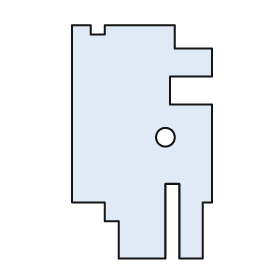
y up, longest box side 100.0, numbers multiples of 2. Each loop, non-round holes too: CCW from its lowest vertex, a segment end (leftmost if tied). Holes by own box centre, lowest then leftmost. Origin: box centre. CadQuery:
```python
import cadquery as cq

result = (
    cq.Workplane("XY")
    .moveTo(-10.0, -50.0)
    .lineTo(10.0, -50.0)
    .lineTo(10.0, -18.0)
    .lineTo(16.0, -18.0)
    .lineTo(16.0, -50.0)
    .lineTo(26.0, -50.0)
    .lineTo(26.0, -26.0)
    .lineTo(30.0, -26.0)
    .lineTo(30.0, 16.0)
    .lineTo(12.0, 16.0)
    .lineTo(12.0, 28.0)
    .lineTo(30.0, 28.0)
    .lineTo(30.0, 40.0)
    .lineTo(14.0, 40.0)
    .lineTo(14.0, 50.0)
    .lineTo(-16.0, 50.0)
    .lineTo(-16.0, 46.0)
    .lineTo(-22.0, 46.0)
    .lineTo(-22.0, 50.0)
    .lineTo(-30.0, 50.0)
    .lineTo(-30.0, -26.0)
    .lineTo(-16.0, -26.0)
    .lineTo(-16.0, -34.0)
    .lineTo(-10.0, -34.0)
    .close()
    .moveTo(10.0, 2.0)
    .circle(4.0)
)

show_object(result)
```